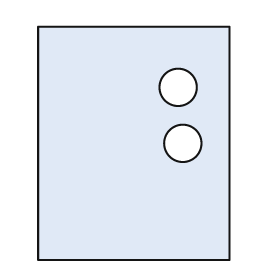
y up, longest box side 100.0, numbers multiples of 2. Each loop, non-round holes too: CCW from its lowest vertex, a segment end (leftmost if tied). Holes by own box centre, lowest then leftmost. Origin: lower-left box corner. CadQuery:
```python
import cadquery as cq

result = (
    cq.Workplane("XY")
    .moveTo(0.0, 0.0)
    .lineTo(82.0, 0.0)
    .lineTo(82.0, 100.0)
    .lineTo(0.0, 100.0)
    .close()
    .moveTo(62.0, 50.0)
    .circle(8.0)
    .moveTo(60.0, 74.0)
    .circle(8.0)
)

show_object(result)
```